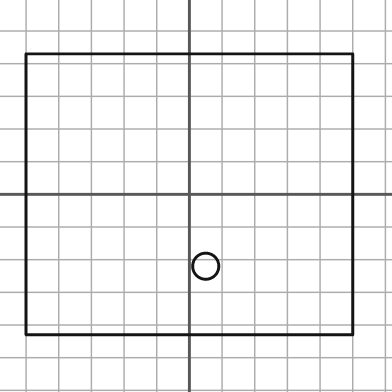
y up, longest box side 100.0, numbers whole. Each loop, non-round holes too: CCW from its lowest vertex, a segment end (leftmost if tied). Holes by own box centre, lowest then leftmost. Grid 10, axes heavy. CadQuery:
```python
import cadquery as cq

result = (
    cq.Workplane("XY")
    .moveTo(-50.0, -43.0)
    .lineTo(50.0, -43.0)
    .lineTo(50.0, 43.0)
    .lineTo(-50.0, 43.0)
    .close()
    .moveTo(5.0, -22.0)
    .circle(4.0)
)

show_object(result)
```